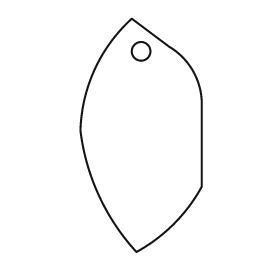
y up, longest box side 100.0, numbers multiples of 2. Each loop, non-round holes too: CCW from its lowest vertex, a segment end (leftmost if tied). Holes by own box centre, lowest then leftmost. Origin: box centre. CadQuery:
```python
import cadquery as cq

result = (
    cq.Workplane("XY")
    .moveTo(-2.0, -50.0)
    .threePointArc((14.0, -38.0), (26.0, -22.0))
    .lineTo(26.0, 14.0)
    .threePointArc((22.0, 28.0), (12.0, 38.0))
    .lineTo(-4.0, 50.0)
    .threePointArc((-20.0, 28.0), (-26.0, 2.0))
    .threePointArc((-18.0, -26.0), (-2.0, -50.0))
    .close()
    .moveTo(0.0, 36.0)
    .circle(4.0)
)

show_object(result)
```